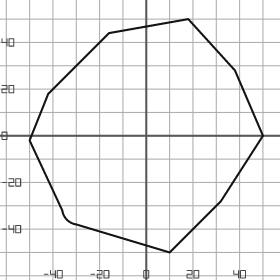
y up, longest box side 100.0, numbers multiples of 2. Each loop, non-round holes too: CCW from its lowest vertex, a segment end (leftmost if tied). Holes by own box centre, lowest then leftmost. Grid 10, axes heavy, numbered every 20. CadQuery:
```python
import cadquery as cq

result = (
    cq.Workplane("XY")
    .moveTo(10.0, -50.0)
    .lineTo(32.0, -28.0)
    .lineTo(50.0, 0.0)
    .lineTo(38.0, 28.0)
    .lineTo(18.0, 50.0)
    .lineTo(-16.0, 44.0)
    .lineTo(-42.0, 18.0)
    .lineTo(-50.0, -2.0)
    .lineTo(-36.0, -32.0)
    .threePointArc((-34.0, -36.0), (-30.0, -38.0))
    .close()
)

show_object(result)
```